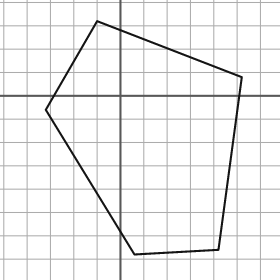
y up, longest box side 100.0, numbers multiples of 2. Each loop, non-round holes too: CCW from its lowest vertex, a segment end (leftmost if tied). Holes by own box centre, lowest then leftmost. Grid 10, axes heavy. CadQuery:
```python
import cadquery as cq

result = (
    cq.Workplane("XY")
    .moveTo(6.0, -68.0)
    .lineTo(42.0, -66.0)
    .lineTo(52.0, 8.0)
    .lineTo(-10.0, 32.0)
    .lineTo(-32.0, -6.0)
    .close()
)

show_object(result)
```